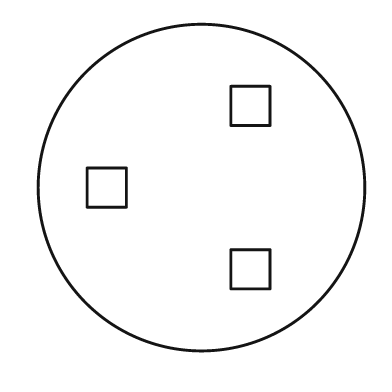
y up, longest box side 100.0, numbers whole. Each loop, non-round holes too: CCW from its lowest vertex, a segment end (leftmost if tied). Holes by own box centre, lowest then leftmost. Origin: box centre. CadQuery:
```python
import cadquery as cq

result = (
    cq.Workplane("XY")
    .moveTo(0.0, 0.0)
    .circle(50.0)
    .moveTo(9.0, -31.0)
    .lineTo(21.0, -31.0)
    .lineTo(21.0, -19.0)
    .lineTo(9.0, -19.0)
    .close()
    .moveTo(-35.0, -6.0)
    .lineTo(-23.0, -6.0)
    .lineTo(-23.0, 6.0)
    .lineTo(-35.0, 6.0)
    .close()
    .moveTo(9.0, 19.0)
    .lineTo(21.0, 19.0)
    .lineTo(21.0, 31.0)
    .lineTo(9.0, 31.0)
    .close()
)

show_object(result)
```